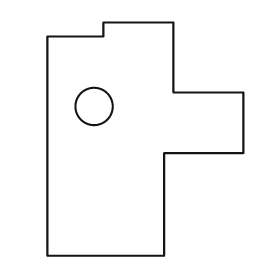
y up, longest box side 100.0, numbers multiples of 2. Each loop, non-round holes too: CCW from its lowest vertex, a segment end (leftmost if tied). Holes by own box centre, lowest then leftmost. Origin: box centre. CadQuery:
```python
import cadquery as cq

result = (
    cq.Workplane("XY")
    .moveTo(-42.0, -50.0)
    .lineTo(8.0, -50.0)
    .lineTo(8.0, -6.0)
    .lineTo(42.0, -6.0)
    .lineTo(42.0, 20.0)
    .lineTo(12.0, 20.0)
    .lineTo(12.0, 50.0)
    .lineTo(-18.0, 50.0)
    .lineTo(-18.0, 44.0)
    .lineTo(-42.0, 44.0)
    .close()
    .moveTo(-22.0, 14.0)
    .circle(8.0)
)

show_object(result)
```